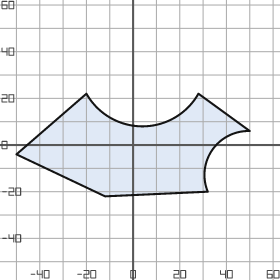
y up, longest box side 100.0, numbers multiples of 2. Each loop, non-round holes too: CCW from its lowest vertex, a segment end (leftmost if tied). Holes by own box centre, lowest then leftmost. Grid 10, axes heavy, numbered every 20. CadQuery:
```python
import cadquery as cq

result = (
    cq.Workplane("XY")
    .moveTo(-12.0, -22.0)
    .lineTo(32.0, -20.0)
    .threePointArc((34.0, -2.0), (50.0, 6.0))
    .lineTo(28.0, 22.0)
    .threePointArc((4.0, 8.0), (-20.0, 22.0))
    .lineTo(-50.0, -4.0)
    .close()
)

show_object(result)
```